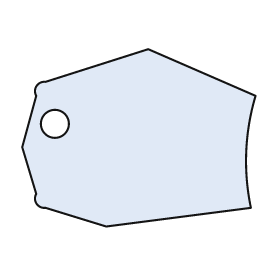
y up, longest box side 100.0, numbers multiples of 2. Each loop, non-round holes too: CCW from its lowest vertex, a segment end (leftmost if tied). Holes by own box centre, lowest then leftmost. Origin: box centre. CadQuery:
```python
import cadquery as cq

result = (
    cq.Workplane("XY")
    .moveTo(-14.0, -38.0)
    .lineTo(48.0, -30.0)
    .threePointArc((46.0, -6.0), (50.0, 18.0))
    .lineTo(4.0, 38.0)
    .lineTo(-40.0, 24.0)
    .threePointArc((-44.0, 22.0), (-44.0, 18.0))
    .lineTo(-50.0, -4.0)
    .lineTo(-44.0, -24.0)
    .threePointArc((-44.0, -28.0), (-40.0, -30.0))
    .close()
    .moveTo(-36.0, 6.0)
    .circle(6.0)
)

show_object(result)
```